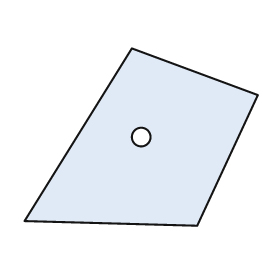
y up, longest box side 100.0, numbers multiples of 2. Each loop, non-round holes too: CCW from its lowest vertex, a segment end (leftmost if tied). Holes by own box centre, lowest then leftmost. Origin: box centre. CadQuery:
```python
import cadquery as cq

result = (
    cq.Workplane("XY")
    .moveTo(24.0, -38.0)
    .lineTo(50.0, 18.0)
    .lineTo(-4.0, 38.0)
    .lineTo(-50.0, -36.0)
    .close()
    .moveTo(0.0, 0.0)
    .circle(4.0)
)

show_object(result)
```